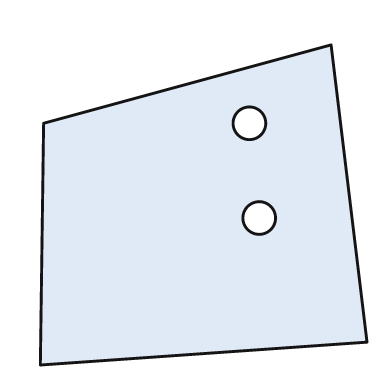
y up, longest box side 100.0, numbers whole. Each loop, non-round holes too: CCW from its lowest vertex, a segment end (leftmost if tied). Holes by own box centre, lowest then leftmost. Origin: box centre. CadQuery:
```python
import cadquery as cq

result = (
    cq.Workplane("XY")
    .moveTo(-50.0, -49.0)
    .lineTo(50.0, -42.0)
    .lineTo(39.0, 49.0)
    .lineTo(-49.0, 25.0)
    .close()
    .moveTo(17.0, -4.0)
    .circle(5.0)
    .moveTo(14.0, 25.0)
    .circle(5.0)
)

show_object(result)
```